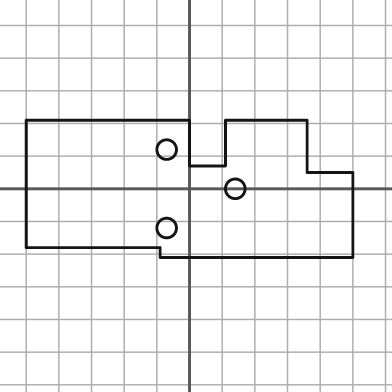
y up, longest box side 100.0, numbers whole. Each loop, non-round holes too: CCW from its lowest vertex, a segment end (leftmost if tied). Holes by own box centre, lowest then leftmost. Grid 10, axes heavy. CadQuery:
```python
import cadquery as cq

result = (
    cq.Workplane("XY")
    .moveTo(-9.0, -21.0)
    .lineTo(50.0, -21.0)
    .lineTo(50.0, 5.0)
    .lineTo(36.0, 5.0)
    .lineTo(36.0, 21.0)
    .lineTo(11.0, 21.0)
    .lineTo(11.0, 7.0)
    .lineTo(0.0, 7.0)
    .lineTo(0.0, 21.0)
    .lineTo(-50.0, 21.0)
    .lineTo(-50.0, -18.0)
    .lineTo(-9.0, -18.0)
    .close()
    .moveTo(-7.0, -12.0)
    .circle(3.0)
    .moveTo(14.0, 0.0)
    .circle(3.0)
    .moveTo(-7.0, 12.0)
    .circle(3.0)
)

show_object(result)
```